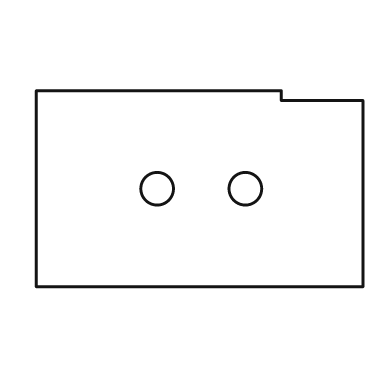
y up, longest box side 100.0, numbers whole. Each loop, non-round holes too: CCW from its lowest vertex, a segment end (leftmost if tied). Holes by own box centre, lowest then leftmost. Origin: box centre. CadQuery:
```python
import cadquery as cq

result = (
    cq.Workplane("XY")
    .moveTo(-50.0, -30.0)
    .lineTo(50.0, -30.0)
    .lineTo(50.0, 27.0)
    .lineTo(25.0, 27.0)
    .lineTo(25.0, 30.0)
    .lineTo(-50.0, 30.0)
    .close()
    .moveTo(-13.0, 0.0)
    .circle(5.0)
    .moveTo(14.0, 0.0)
    .circle(5.0)
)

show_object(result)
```